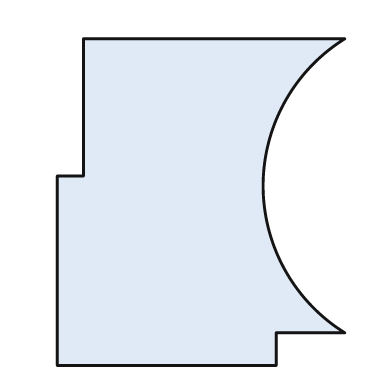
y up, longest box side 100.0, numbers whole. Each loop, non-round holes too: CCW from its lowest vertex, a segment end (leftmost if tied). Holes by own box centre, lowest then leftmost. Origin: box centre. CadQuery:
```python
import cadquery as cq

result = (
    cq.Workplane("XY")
    .moveTo(-44.0, -50.0)
    .lineTo(23.0, -50.0)
    .lineTo(23.0, -40.0)
    .lineTo(44.0, -40.0)
    .threePointArc((19.0, 5.0), (44.0, 50.0))
    .lineTo(-36.0, 50.0)
    .lineTo(-36.0, 8.0)
    .lineTo(-44.0, 8.0)
    .close()
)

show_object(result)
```